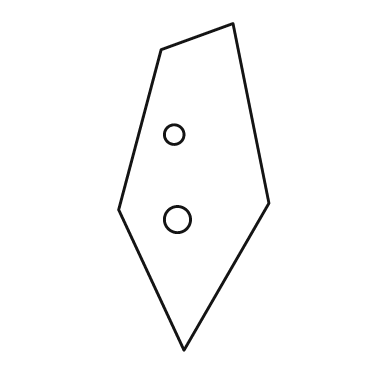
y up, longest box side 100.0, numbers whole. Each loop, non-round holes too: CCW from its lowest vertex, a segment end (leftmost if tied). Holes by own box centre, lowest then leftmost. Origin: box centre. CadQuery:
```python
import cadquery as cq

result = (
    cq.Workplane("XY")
    .moveTo(-3.0, -50.0)
    .lineTo(23.0, -5.0)
    .lineTo(12.0, 50.0)
    .lineTo(-10.0, 42.0)
    .lineTo(-23.0, -7.0)
    .close()
    .moveTo(-5.0, -10.0)
    .circle(4.0)
    .moveTo(-6.0, 16.0)
    .circle(3.0)
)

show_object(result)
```